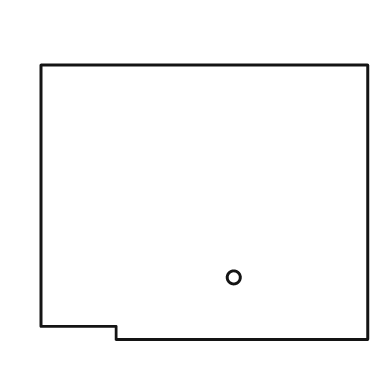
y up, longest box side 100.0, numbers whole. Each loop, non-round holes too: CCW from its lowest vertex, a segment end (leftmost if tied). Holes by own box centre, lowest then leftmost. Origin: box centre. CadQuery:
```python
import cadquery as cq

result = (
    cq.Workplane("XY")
    .moveTo(-27.0, -42.0)
    .lineTo(50.0, -42.0)
    .lineTo(50.0, 42.0)
    .lineTo(-50.0, 42.0)
    .lineTo(-50.0, -38.0)
    .lineTo(-27.0, -38.0)
    .close()
    .moveTo(9.0, -23.0)
    .circle(2.0)
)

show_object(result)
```